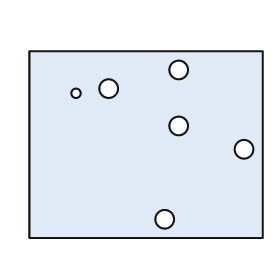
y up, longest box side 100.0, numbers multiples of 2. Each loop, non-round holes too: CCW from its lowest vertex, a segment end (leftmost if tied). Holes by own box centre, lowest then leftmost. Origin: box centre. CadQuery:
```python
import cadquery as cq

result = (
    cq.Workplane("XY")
    .moveTo(-50.0, -40.0)
    .lineTo(50.0, -40.0)
    .lineTo(50.0, 40.0)
    .lineTo(-50.0, 40.0)
    .close()
    .moveTo(8.0, -32.0)
    .circle(4.0)
    .moveTo(42.0, -2.0)
    .circle(4.0)
    .moveTo(14.0, 8.0)
    .circle(4.0)
    .moveTo(-30.0, 22.0)
    .circle(2.0)
    .moveTo(-16.0, 24.0)
    .circle(4.0)
    .moveTo(14.0, 32.0)
    .circle(4.0)
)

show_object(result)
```